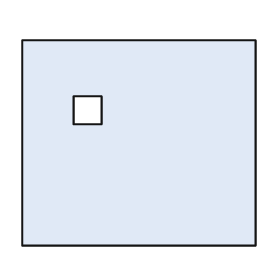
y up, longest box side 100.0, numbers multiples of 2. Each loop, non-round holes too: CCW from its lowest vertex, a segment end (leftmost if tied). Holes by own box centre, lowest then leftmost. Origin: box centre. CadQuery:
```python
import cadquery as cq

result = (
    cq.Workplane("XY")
    .moveTo(-50.0, -44.0)
    .lineTo(50.0, -44.0)
    .lineTo(50.0, 44.0)
    .lineTo(-50.0, 44.0)
    .close()
    .moveTo(-28.0, 8.0)
    .lineTo(-16.0, 8.0)
    .lineTo(-16.0, 20.0)
    .lineTo(-28.0, 20.0)
    .close()
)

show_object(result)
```